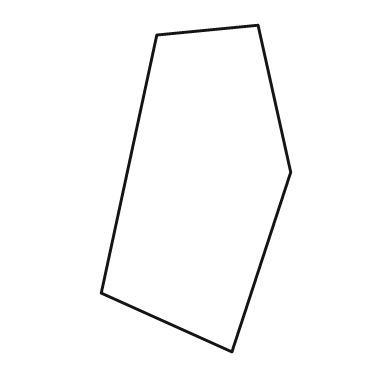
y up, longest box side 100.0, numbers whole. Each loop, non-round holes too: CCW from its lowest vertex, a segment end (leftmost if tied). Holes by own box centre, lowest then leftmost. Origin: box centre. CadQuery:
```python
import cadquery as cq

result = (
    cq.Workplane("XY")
    .moveTo(11.0, -50.0)
    .lineTo(29.0, 5.0)
    .lineTo(19.0, 50.0)
    .lineTo(-12.0, 47.0)
    .lineTo(-29.0, -32.0)
    .close()
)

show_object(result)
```